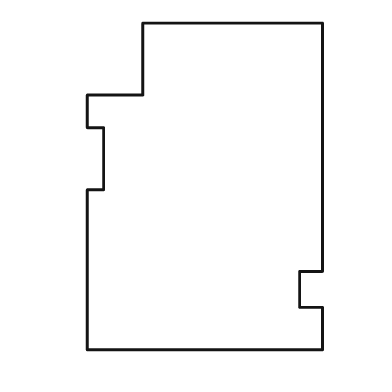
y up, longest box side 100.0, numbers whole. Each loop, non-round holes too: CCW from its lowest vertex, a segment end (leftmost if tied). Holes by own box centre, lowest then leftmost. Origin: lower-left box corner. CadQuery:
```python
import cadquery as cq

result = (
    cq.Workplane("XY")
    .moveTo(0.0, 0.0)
    .lineTo(72.0, 0.0)
    .lineTo(72.0, 13.0)
    .lineTo(65.0, 13.0)
    .lineTo(65.0, 24.0)
    .lineTo(72.0, 24.0)
    .lineTo(72.0, 100.0)
    .lineTo(17.0, 100.0)
    .lineTo(17.0, 78.0)
    .lineTo(0.0, 78.0)
    .lineTo(0.0, 68.0)
    .lineTo(5.0, 68.0)
    .lineTo(5.0, 49.0)
    .lineTo(0.0, 49.0)
    .close()
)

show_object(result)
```